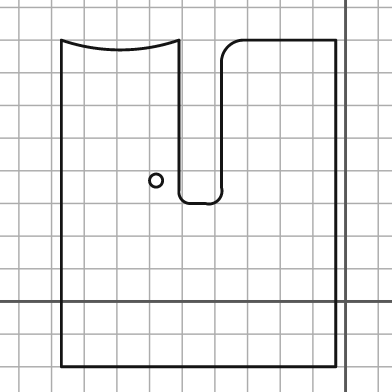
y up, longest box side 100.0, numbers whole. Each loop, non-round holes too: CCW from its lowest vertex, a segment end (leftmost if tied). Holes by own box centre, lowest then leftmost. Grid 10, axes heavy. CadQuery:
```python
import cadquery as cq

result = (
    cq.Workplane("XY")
    .moveTo(-87.0, -20.0)
    .lineTo(-3.0, -20.0)
    .lineTo(-3.0, 80.0)
    .lineTo(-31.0, 80.0)
    .threePointArc((-36.0, 78.0), (-38.0, 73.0))
    .lineTo(-38.0, 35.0)
    .threePointArc((-39.0, 31.0), (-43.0, 30.0))
    .lineTo(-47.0, 30.0)
    .threePointArc((-50.0, 31.0), (-51.0, 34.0))
    .lineTo(-51.0, 80.0)
    .threePointArc((-69.0, 77.0), (-87.0, 80.0))
    .close()
    .moveTo(-58.0, 37.0)
    .circle(2.0)
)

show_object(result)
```